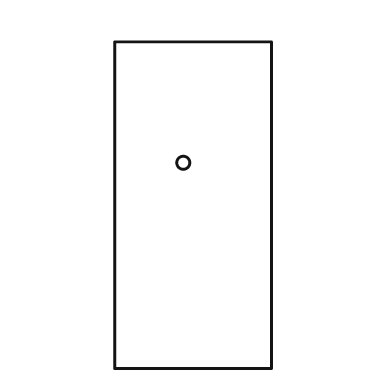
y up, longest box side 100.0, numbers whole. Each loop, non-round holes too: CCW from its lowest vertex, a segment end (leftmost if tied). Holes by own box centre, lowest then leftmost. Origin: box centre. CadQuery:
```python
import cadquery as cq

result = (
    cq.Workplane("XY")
    .moveTo(-24.0, -50.0)
    .lineTo(24.0, -50.0)
    .lineTo(24.0, 50.0)
    .lineTo(-24.0, 50.0)
    .close()
    .moveTo(-3.0, 13.0)
    .circle(2.0)
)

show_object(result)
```